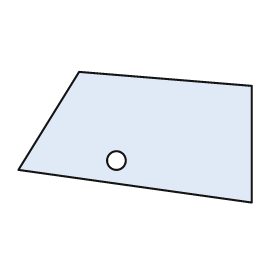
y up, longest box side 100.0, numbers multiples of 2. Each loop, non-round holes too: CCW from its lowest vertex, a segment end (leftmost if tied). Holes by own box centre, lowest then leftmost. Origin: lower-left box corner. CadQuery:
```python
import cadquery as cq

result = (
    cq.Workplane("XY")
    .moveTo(100.0, 0.0)
    .lineTo(100.0, 50.0)
    .lineTo(26.0, 56.0)
    .lineTo(0.0, 14.0)
    .close()
    .moveTo(42.0, 18.0)
    .circle(4.0)
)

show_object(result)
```